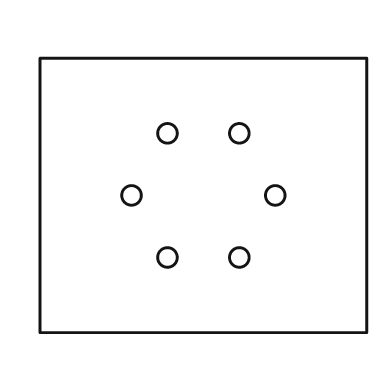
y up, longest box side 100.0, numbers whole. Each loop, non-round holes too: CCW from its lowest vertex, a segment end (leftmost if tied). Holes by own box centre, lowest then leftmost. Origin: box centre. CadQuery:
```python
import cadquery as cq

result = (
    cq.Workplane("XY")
    .moveTo(-50.0, -42.0)
    .lineTo(50.0, -42.0)
    .lineTo(50.0, 42.0)
    .lineTo(-50.0, 42.0)
    .close()
    .moveTo(-11.0, -19.0)
    .circle(3.0)
    .moveTo(11.0, -19.0)
    .circle(3.0)
    .moveTo(-22.0, 0.0)
    .circle(3.0)
    .moveTo(22.0, 0.0)
    .circle(3.0)
    .moveTo(-11.0, 19.0)
    .circle(3.0)
    .moveTo(11.0, 19.0)
    .circle(3.0)
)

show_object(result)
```